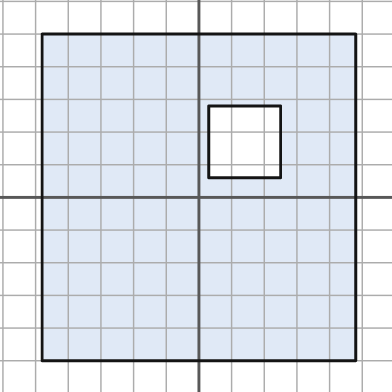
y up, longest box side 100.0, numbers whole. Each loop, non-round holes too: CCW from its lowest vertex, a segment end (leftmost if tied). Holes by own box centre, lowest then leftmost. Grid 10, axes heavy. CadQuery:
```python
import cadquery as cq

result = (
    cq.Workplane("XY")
    .moveTo(-48.0, -50.0)
    .lineTo(48.0, -50.0)
    .lineTo(48.0, 50.0)
    .lineTo(-48.0, 50.0)
    .close()
    .moveTo(3.0, 6.0)
    .lineTo(25.0, 6.0)
    .lineTo(25.0, 28.0)
    .lineTo(3.0, 28.0)
    .close()
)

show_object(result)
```